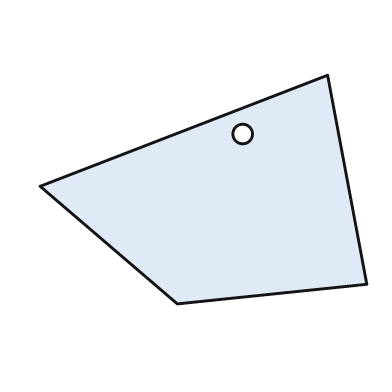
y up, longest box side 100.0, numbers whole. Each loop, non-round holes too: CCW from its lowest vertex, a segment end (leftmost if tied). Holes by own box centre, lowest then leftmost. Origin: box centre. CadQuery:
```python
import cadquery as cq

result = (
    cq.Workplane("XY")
    .moveTo(-8.0, -35.0)
    .lineTo(50.0, -29.0)
    .lineTo(38.0, 35.0)
    .lineTo(-50.0, 1.0)
    .close()
    .moveTo(12.0, 17.0)
    .circle(3.0)
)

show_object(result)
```